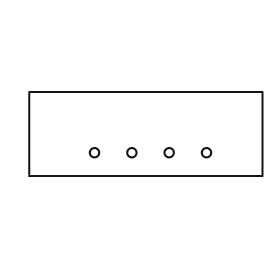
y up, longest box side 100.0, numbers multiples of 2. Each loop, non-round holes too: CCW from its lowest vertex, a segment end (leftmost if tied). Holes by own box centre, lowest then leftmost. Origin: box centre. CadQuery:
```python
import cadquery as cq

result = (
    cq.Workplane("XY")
    .moveTo(-50.0, -18.0)
    .lineTo(50.0, -18.0)
    .lineTo(50.0, 18.0)
    .lineTo(-50.0, 18.0)
    .close()
    .moveTo(-22.0, -8.0)
    .circle(2.0)
    .moveTo(-6.0, -8.0)
    .circle(2.0)
    .moveTo(10.0, -8.0)
    .circle(2.0)
    .moveTo(26.0, -8.0)
    .circle(2.0)
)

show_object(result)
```